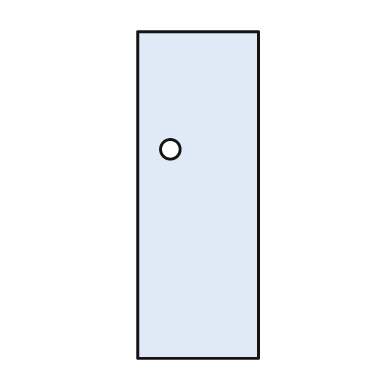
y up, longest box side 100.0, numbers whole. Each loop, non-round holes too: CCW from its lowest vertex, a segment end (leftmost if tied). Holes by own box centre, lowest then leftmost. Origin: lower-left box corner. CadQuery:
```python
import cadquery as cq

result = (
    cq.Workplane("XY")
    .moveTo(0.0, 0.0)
    .lineTo(37.0, 0.0)
    .lineTo(37.0, 100.0)
    .lineTo(0.0, 100.0)
    .close()
    .moveTo(10.0, 64.0)
    .circle(3.0)
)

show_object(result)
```